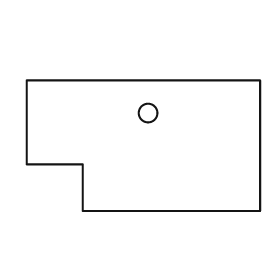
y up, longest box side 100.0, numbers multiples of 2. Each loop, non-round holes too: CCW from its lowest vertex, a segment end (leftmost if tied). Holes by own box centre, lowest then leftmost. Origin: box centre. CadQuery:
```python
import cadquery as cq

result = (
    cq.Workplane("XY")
    .moveTo(-26.0, -28.0)
    .lineTo(50.0, -28.0)
    .lineTo(50.0, 28.0)
    .lineTo(-50.0, 28.0)
    .lineTo(-50.0, -8.0)
    .lineTo(-26.0, -8.0)
    .close()
    .moveTo(2.0, 14.0)
    .circle(4.0)
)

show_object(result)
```